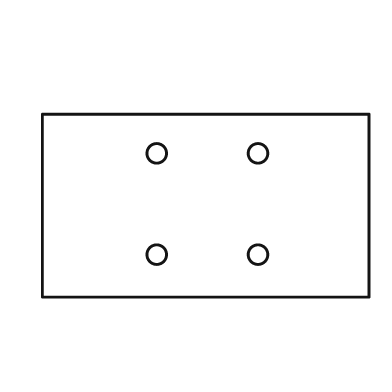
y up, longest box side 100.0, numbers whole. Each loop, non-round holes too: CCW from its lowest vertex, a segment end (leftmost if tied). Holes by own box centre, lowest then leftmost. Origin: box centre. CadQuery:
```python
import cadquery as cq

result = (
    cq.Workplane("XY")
    .moveTo(-50.0, -28.0)
    .lineTo(50.0, -28.0)
    .lineTo(50.0, 28.0)
    .lineTo(-50.0, 28.0)
    .close()
    .moveTo(-15.0, -15.0)
    .circle(3.0)
    .moveTo(16.0, -15.0)
    .circle(3.0)
    .moveTo(-15.0, 16.0)
    .circle(3.0)
    .moveTo(16.0, 16.0)
    .circle(3.0)
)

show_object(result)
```